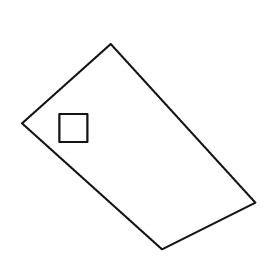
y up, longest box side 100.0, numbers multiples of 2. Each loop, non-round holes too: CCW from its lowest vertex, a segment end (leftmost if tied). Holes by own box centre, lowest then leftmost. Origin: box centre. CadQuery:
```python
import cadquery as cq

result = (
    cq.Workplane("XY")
    .moveTo(10.0, -44.0)
    .lineTo(50.0, -24.0)
    .lineTo(-12.0, 44.0)
    .lineTo(-50.0, 10.0)
    .close()
    .moveTo(-34.0, 2.0)
    .lineTo(-22.0, 2.0)
    .lineTo(-22.0, 14.0)
    .lineTo(-34.0, 14.0)
    .close()
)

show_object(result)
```